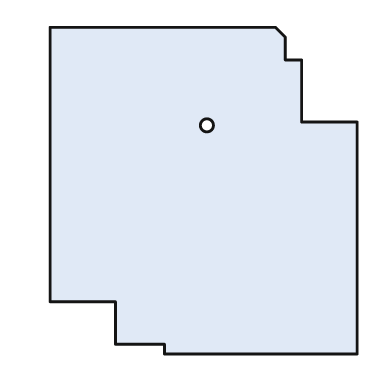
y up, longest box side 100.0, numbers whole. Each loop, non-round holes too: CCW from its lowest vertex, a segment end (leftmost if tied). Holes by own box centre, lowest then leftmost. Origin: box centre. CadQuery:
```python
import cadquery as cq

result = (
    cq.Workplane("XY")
    .moveTo(-12.0, -50.0)
    .lineTo(47.0, -50.0)
    .lineTo(47.0, 21.0)
    .lineTo(30.0, 21.0)
    .lineTo(30.0, 40.0)
    .lineTo(25.0, 40.0)
    .lineTo(25.0, 47.0)
    .lineTo(22.0, 50.0)
    .lineTo(-47.0, 50.0)
    .lineTo(-47.0, -34.0)
    .lineTo(-27.0, -34.0)
    .lineTo(-27.0, -47.0)
    .lineTo(-12.0, -47.0)
    .close()
    .moveTo(1.0, 20.0)
    .circle(2.0)
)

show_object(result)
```